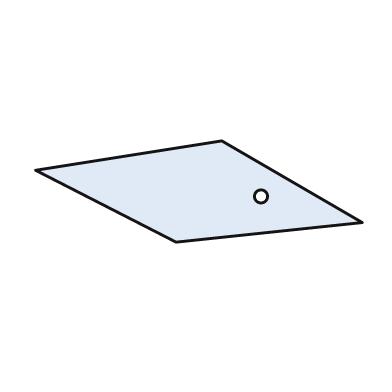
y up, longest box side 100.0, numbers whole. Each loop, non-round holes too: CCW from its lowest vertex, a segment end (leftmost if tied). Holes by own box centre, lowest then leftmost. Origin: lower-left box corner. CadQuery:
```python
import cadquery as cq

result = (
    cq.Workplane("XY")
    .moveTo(43.0, 0.0)
    .lineTo(100.0, 6.0)
    .lineTo(57.0, 31.0)
    .lineTo(0.0, 22.0)
    .close()
    .moveTo(69.0, 14.0)
    .circle(2.0)
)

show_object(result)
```